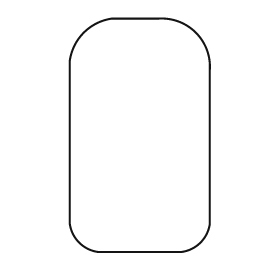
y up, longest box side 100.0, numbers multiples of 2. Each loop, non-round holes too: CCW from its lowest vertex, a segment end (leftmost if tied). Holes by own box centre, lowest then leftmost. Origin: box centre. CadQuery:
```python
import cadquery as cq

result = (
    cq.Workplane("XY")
    .moveTo(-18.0, -50.0)
    .lineTo(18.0, -50.0)
    .threePointArc((26.0, -46.0), (30.0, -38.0))
    .lineTo(30.0, 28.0)
    .threePointArc((24.0, 44.0), (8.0, 50.0))
    .lineTo(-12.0, 50.0)
    .threePointArc((-24.0, 44.0), (-30.0, 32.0))
    .lineTo(-30.0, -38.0)
    .threePointArc((-26.0, -46.0), (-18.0, -50.0))
    .close()
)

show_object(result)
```